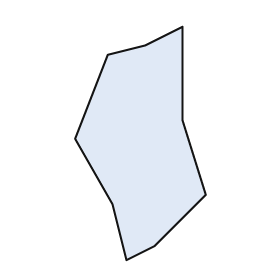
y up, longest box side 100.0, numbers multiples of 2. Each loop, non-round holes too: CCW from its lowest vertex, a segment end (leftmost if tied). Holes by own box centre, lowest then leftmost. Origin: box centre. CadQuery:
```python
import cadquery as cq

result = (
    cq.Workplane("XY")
    .moveTo(-6.0, -50.0)
    .lineTo(6.0, -44.0)
    .lineTo(28.0, -22.0)
    .lineTo(18.0, 10.0)
    .lineTo(18.0, 50.0)
    .lineTo(2.0, 42.0)
    .lineTo(-14.0, 38.0)
    .lineTo(-28.0, 2.0)
    .lineTo(-12.0, -26.0)
    .close()
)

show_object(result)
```